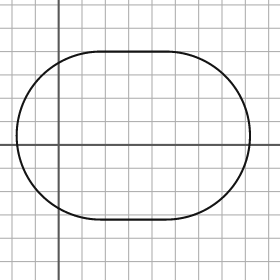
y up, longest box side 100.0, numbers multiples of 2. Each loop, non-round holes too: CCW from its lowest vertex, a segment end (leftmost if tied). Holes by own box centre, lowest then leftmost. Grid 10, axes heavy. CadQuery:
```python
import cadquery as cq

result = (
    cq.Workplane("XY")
    .moveTo(18.0, -32.0)
    .lineTo(46.0, -32.0)
    .threePointArc((82.0, 4.0), (46.0, 40.0))
    .lineTo(18.0, 40.0)
    .threePointArc((-18.0, 4.0), (18.0, -32.0))
    .close()
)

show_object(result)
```